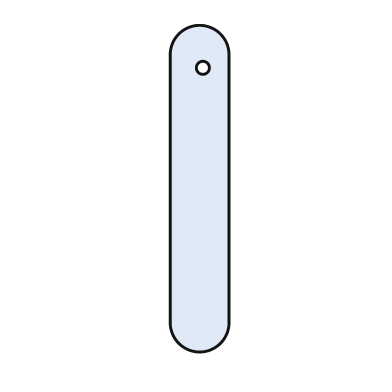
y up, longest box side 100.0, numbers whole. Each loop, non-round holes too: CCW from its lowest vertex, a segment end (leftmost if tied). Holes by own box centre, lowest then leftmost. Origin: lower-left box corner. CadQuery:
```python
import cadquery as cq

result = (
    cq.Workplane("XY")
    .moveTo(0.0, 9.0)
    .threePointArc((9.0, 0.0), (18.0, 9.0))
    .lineTo(18.0, 91.0)
    .threePointArc((9.0, 100.0), (0.0, 91.0))
    .close()
    .moveTo(10.0, 87.0)
    .circle(2.0)
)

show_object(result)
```